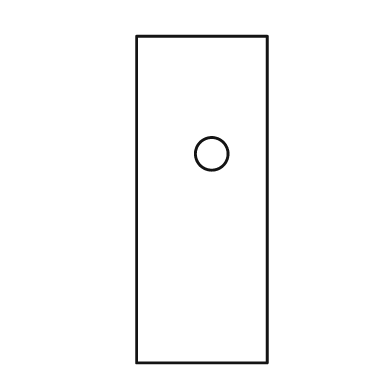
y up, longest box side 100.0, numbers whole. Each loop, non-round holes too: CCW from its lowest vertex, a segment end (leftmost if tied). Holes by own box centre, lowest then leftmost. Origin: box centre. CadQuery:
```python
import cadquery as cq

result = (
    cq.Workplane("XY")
    .moveTo(-20.0, -50.0)
    .lineTo(20.0, -50.0)
    .lineTo(20.0, 50.0)
    .lineTo(-20.0, 50.0)
    .close()
    .moveTo(3.0, 14.0)
    .circle(5.0)
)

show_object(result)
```